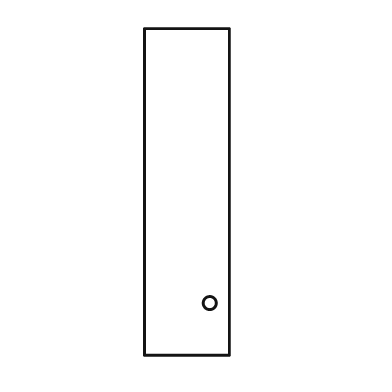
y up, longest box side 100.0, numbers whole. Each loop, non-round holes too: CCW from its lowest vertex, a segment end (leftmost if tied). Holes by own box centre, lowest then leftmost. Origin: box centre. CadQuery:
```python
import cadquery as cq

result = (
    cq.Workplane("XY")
    .moveTo(-13.0, -50.0)
    .lineTo(13.0, -50.0)
    .lineTo(13.0, 50.0)
    .lineTo(-13.0, 50.0)
    .close()
    .moveTo(7.0, -34.0)
    .circle(2.0)
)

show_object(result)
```